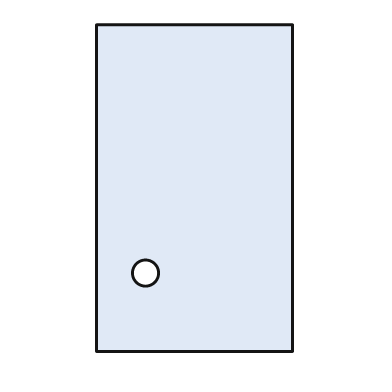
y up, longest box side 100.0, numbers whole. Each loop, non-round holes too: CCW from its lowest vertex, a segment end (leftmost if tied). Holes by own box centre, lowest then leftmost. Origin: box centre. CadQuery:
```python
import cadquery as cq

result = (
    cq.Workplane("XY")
    .moveTo(-30.0, -50.0)
    .lineTo(30.0, -50.0)
    .lineTo(30.0, 50.0)
    .lineTo(-30.0, 50.0)
    .close()
    .moveTo(-15.0, -26.0)
    .circle(4.0)
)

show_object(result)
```